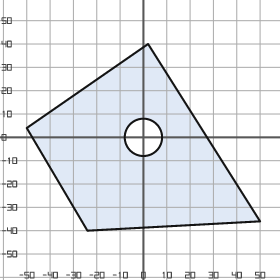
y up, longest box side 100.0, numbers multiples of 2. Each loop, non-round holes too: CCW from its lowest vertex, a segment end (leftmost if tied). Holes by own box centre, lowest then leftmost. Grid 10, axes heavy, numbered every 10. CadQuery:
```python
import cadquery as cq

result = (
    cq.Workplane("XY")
    .moveTo(-24.0, -40.0)
    .lineTo(50.0, -36.0)
    .lineTo(2.0, 40.0)
    .lineTo(-50.0, 4.0)
    .close()
    .moveTo(0.0, 0.0)
    .circle(8.0)
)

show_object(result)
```